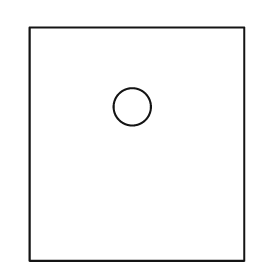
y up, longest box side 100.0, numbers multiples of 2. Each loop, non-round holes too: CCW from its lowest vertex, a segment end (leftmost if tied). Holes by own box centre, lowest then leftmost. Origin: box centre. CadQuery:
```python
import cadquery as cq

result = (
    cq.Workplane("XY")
    .moveTo(-46.0, -50.0)
    .lineTo(46.0, -50.0)
    .lineTo(46.0, 50.0)
    .lineTo(-46.0, 50.0)
    .close()
    .moveTo(-2.0, 16.0)
    .circle(8.0)
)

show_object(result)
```